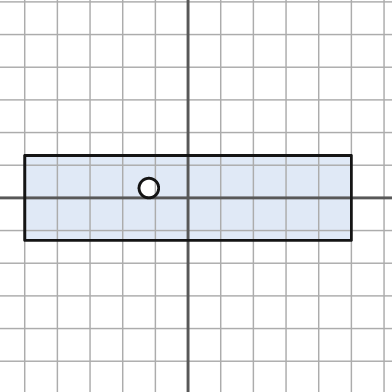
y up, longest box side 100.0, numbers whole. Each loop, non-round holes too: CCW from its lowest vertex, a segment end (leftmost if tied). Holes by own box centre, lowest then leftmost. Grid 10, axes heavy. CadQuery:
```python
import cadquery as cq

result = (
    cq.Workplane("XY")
    .moveTo(-50.0, -13.0)
    .lineTo(50.0, -13.0)
    .lineTo(50.0, 13.0)
    .lineTo(-50.0, 13.0)
    .close()
    .moveTo(-12.0, 3.0)
    .circle(3.0)
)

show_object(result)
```